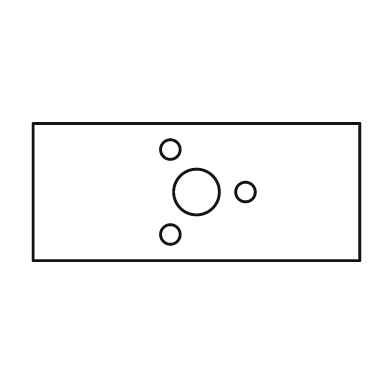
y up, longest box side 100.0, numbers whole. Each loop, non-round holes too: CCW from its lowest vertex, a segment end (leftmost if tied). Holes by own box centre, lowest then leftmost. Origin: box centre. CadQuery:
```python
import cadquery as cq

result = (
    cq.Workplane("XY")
    .moveTo(-50.0, -21.0)
    .lineTo(50.0, -21.0)
    .lineTo(50.0, 21.0)
    .lineTo(-50.0, 21.0)
    .close()
    .moveTo(-8.0, -13.0)
    .circle(3.0)
    .moveTo(0.0, 0.0)
    .circle(7.0)
    .moveTo(15.0, 0.0)
    .circle(3.0)
    .moveTo(-8.0, 13.0)
    .circle(3.0)
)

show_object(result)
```